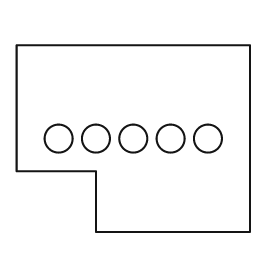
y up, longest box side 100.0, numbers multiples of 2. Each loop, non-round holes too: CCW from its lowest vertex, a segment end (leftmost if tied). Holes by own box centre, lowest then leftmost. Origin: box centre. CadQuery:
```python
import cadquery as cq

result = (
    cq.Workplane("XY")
    .moveTo(-16.0, -40.0)
    .lineTo(50.0, -40.0)
    .lineTo(50.0, 40.0)
    .lineTo(-50.0, 40.0)
    .lineTo(-50.0, -14.0)
    .lineTo(-16.0, -14.0)
    .close()
    .moveTo(-32.0, 0.0)
    .circle(6.0)
    .moveTo(-16.0, 0.0)
    .circle(6.0)
    .moveTo(0.0, 0.0)
    .circle(6.0)
    .moveTo(16.0, 0.0)
    .circle(6.0)
    .moveTo(32.0, 0.0)
    .circle(6.0)
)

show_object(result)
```